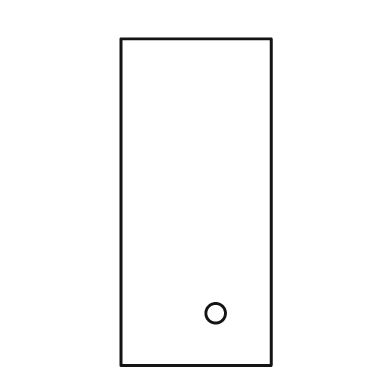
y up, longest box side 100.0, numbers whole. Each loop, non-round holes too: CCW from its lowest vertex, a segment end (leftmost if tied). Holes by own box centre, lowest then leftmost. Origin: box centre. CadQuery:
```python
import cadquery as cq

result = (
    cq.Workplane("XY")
    .moveTo(-23.0, -50.0)
    .lineTo(23.0, -50.0)
    .lineTo(23.0, 50.0)
    .lineTo(-23.0, 50.0)
    .close()
    .moveTo(6.0, -34.0)
    .circle(3.0)
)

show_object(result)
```